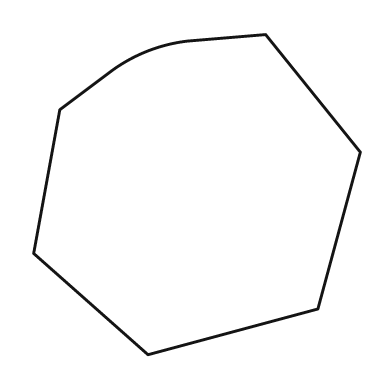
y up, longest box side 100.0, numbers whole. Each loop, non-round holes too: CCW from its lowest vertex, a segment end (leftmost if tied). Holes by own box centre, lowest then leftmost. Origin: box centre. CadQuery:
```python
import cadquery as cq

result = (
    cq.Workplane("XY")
    .moveTo(-15.0, -49.0)
    .lineTo(37.0, -35.0)
    .lineTo(50.0, 13.0)
    .lineTo(21.0, 49.0)
    .lineTo(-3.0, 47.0)
    .threePointArc((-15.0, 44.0), (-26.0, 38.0))
    .lineTo(-42.0, 26.0)
    .lineTo(-50.0, -18.0)
    .close()
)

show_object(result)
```